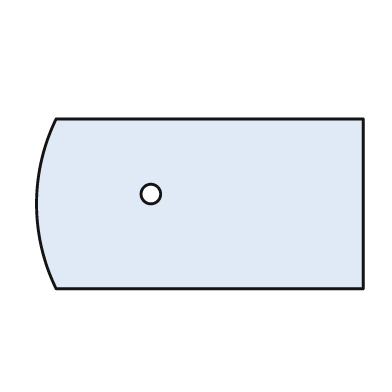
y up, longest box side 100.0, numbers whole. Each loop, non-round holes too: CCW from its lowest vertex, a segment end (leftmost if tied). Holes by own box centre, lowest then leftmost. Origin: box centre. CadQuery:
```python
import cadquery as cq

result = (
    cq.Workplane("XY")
    .moveTo(-44.0, -26.0)
    .lineTo(50.0, -26.0)
    .lineTo(50.0, 26.0)
    .lineTo(-44.0, 26.0)
    .threePointArc((-50.0, 0.0), (-44.0, -26.0))
    .close()
    .moveTo(-15.0, 3.0)
    .circle(3.0)
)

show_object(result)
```